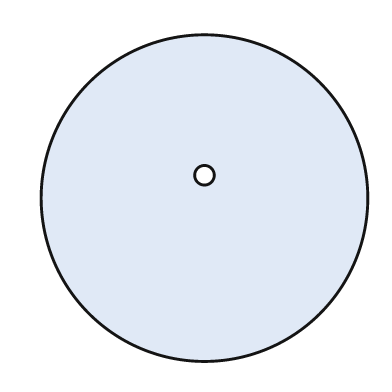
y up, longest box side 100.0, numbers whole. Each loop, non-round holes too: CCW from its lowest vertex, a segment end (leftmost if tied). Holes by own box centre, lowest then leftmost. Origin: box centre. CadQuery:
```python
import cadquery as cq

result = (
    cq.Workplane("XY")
    .moveTo(0.0, 0.0)
    .circle(50.0)
    .moveTo(0.0, 7.0)
    .circle(3.0)
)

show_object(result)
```